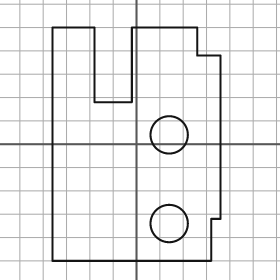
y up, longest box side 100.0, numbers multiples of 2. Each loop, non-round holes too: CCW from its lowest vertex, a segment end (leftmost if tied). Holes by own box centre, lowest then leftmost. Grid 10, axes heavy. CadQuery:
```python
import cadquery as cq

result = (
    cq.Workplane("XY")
    .moveTo(-36.0, -50.0)
    .lineTo(32.0, -50.0)
    .lineTo(32.0, -32.0)
    .lineTo(36.0, -32.0)
    .lineTo(36.0, 38.0)
    .lineTo(26.0, 38.0)
    .lineTo(26.0, 50.0)
    .lineTo(-2.0, 50.0)
    .lineTo(-2.0, 18.0)
    .lineTo(-18.0, 18.0)
    .lineTo(-18.0, 50.0)
    .lineTo(-36.0, 50.0)
    .close()
    .moveTo(14.0, -34.0)
    .circle(8.0)
    .moveTo(14.0, 4.0)
    .circle(8.0)
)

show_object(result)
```